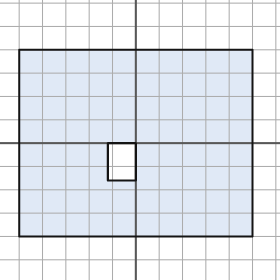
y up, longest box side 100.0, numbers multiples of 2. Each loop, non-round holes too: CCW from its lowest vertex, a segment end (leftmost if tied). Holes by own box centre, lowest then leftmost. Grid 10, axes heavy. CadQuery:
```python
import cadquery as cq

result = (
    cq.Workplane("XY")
    .moveTo(-50.0, -40.0)
    .lineTo(50.0, -40.0)
    .lineTo(50.0, 40.0)
    .lineTo(-50.0, 40.0)
    .close()
    .moveTo(-12.0, -16.0)
    .lineTo(0.0, -16.0)
    .lineTo(0.0, 0.0)
    .lineTo(-12.0, 0.0)
    .close()
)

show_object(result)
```